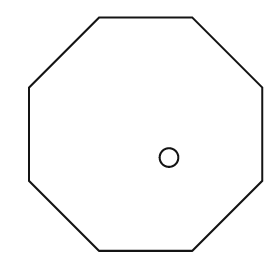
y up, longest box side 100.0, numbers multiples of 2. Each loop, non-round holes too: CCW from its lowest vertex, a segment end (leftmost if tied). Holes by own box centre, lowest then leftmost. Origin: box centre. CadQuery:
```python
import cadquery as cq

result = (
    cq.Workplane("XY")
    .moveTo(-20.0, -50.0)
    .lineTo(20.0, -50.0)
    .lineTo(50.0, -20.0)
    .lineTo(50.0, 20.0)
    .lineTo(20.0, 50.0)
    .lineTo(-20.0, 50.0)
    .lineTo(-50.0, 20.0)
    .lineTo(-50.0, -20.0)
    .close()
    .moveTo(10.0, -10.0)
    .circle(4.0)
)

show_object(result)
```